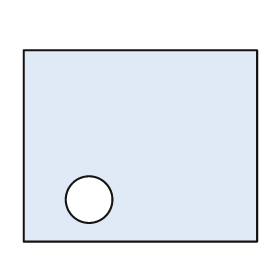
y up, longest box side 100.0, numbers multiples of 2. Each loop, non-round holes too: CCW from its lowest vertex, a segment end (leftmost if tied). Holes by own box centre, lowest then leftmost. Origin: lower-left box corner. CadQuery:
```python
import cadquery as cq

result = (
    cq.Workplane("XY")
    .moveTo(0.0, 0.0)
    .lineTo(100.0, 0.0)
    .lineTo(100.0, 82.0)
    .lineTo(0.0, 82.0)
    .close()
    .moveTo(28.0, 18.0)
    .circle(10.0)
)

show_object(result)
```